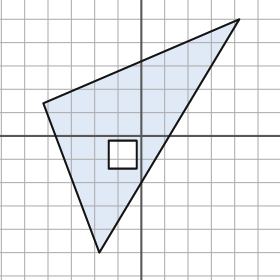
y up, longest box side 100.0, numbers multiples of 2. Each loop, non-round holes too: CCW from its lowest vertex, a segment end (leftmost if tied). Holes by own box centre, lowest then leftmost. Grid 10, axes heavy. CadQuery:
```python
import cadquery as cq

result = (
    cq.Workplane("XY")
    .moveTo(-18.0, -50.0)
    .lineTo(42.0, 50.0)
    .lineTo(-42.0, 14.0)
    .close()
    .moveTo(-14.0, -14.0)
    .lineTo(-2.0, -14.0)
    .lineTo(-2.0, -2.0)
    .lineTo(-14.0, -2.0)
    .close()
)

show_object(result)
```